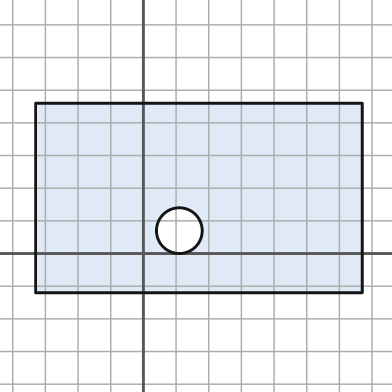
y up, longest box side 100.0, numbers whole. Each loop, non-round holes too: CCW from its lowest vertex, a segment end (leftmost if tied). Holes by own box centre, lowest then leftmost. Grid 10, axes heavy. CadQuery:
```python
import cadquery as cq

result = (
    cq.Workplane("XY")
    .moveTo(-33.0, -12.0)
    .lineTo(67.0, -12.0)
    .lineTo(67.0, 46.0)
    .lineTo(-33.0, 46.0)
    .close()
    .moveTo(11.0, 7.0)
    .circle(7.0)
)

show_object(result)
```